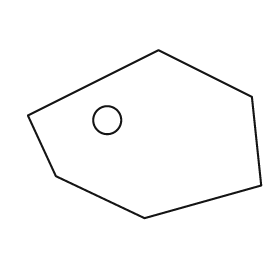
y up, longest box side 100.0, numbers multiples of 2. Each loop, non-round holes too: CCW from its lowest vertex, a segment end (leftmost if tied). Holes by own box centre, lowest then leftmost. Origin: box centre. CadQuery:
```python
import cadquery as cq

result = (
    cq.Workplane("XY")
    .moveTo(0.0, -36.0)
    .lineTo(50.0, -22.0)
    .lineTo(46.0, 16.0)
    .lineTo(6.0, 36.0)
    .lineTo(-50.0, 8.0)
    .lineTo(-38.0, -18.0)
    .close()
    .moveTo(-16.0, 6.0)
    .circle(6.0)
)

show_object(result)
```